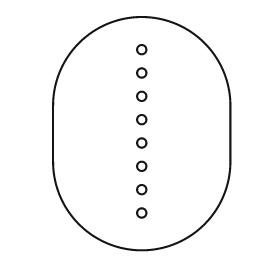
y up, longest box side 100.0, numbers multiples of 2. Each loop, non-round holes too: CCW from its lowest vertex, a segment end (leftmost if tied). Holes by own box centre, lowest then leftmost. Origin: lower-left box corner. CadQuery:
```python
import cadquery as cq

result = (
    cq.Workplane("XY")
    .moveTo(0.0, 38.0)
    .threePointArc((38.0, 0.0), (76.0, 38.0))
    .lineTo(76.0, 62.0)
    .threePointArc((38.0, 100.0), (0.0, 62.0))
    .close()
    .moveTo(38.0, 16.0)
    .circle(2.0)
    .moveTo(38.0, 26.0)
    .circle(2.0)
    .moveTo(38.0, 36.0)
    .circle(2.0)
    .moveTo(38.0, 46.0)
    .circle(2.0)
    .moveTo(38.0, 56.0)
    .circle(2.0)
    .moveTo(38.0, 66.0)
    .circle(2.0)
    .moveTo(38.0, 76.0)
    .circle(2.0)
    .moveTo(38.0, 86.0)
    .circle(2.0)
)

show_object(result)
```